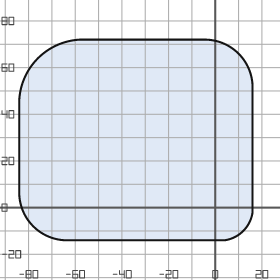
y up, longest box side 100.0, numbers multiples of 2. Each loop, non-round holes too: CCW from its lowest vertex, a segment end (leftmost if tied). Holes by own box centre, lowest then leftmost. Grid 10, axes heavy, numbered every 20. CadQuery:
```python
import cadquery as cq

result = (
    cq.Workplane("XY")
    .moveTo(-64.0, -14.0)
    .lineTo(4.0, -14.0)
    .threePointArc((12.0, -10.0), (16.0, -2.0))
    .lineTo(16.0, 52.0)
    .threePointArc((10.0, 66.0), (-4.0, 72.0))
    .lineTo(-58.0, 72.0)
    .threePointArc((-76.0, 64.0), (-84.0, 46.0))
    .lineTo(-84.0, 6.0)
    .threePointArc((-78.0, -8.0), (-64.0, -14.0))
    .close()
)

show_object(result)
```